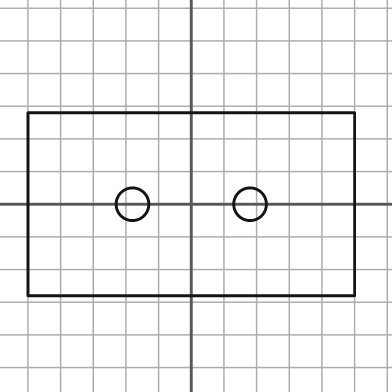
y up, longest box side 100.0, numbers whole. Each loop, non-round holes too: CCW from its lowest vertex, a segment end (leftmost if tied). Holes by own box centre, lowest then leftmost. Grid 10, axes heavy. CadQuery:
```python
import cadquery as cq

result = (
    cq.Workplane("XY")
    .moveTo(-50.0, -28.0)
    .lineTo(50.0, -28.0)
    .lineTo(50.0, 28.0)
    .lineTo(-50.0, 28.0)
    .close()
    .moveTo(-18.0, 0.0)
    .circle(5.0)
    .moveTo(18.0, 0.0)
    .circle(5.0)
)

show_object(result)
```